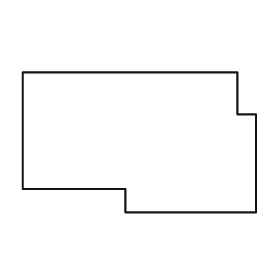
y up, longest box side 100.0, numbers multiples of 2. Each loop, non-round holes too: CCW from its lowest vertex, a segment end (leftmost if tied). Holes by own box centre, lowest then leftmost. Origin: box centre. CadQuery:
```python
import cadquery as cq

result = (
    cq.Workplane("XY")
    .moveTo(-6.0, -30.0)
    .lineTo(50.0, -30.0)
    .lineTo(50.0, 12.0)
    .lineTo(42.0, 12.0)
    .lineTo(42.0, 30.0)
    .lineTo(-50.0, 30.0)
    .lineTo(-50.0, -20.0)
    .lineTo(-6.0, -20.0)
    .close()
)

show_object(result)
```